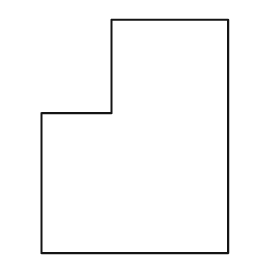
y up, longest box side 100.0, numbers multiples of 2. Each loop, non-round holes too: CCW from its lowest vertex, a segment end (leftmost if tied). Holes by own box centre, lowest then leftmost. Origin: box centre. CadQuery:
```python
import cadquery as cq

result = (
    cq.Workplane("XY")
    .moveTo(-40.0, -50.0)
    .lineTo(40.0, -50.0)
    .lineTo(40.0, 50.0)
    .lineTo(-10.0, 50.0)
    .lineTo(-10.0, 10.0)
    .lineTo(-40.0, 10.0)
    .close()
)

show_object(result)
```